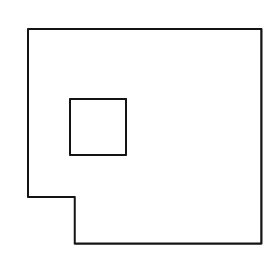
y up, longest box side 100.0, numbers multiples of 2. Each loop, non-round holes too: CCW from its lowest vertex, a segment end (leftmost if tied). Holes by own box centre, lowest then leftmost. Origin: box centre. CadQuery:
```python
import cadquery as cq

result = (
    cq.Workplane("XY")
    .moveTo(-30.0, -46.0)
    .lineTo(50.0, -46.0)
    .lineTo(50.0, 46.0)
    .lineTo(-50.0, 46.0)
    .lineTo(-50.0, -26.0)
    .lineTo(-30.0, -26.0)
    .close()
    .moveTo(-32.0, -8.0)
    .lineTo(-8.0, -8.0)
    .lineTo(-8.0, 16.0)
    .lineTo(-32.0, 16.0)
    .close()
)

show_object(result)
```